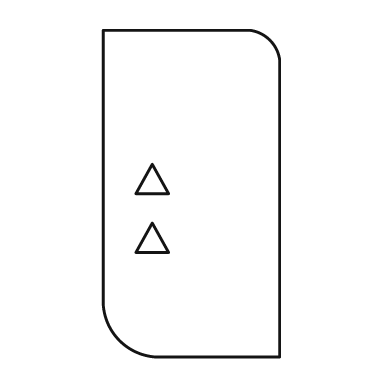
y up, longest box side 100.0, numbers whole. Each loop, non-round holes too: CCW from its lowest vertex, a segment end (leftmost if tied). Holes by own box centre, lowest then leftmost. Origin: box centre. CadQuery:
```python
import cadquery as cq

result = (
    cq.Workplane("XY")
    .moveTo(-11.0, -50.0)
    .lineTo(27.0, -50.0)
    .lineTo(27.0, 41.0)
    .threePointArc((24.0, 47.0), (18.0, 50.0))
    .lineTo(-27.0, 50.0)
    .lineTo(-27.0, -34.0)
    .threePointArc((-22.0, -45.0), (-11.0, -50.0))
    .close()
    .moveTo(-17.0, -18.0)
    .lineTo(-7.0, -18.0)
    .lineTo(-12.0, -9.0)
    .close()
    .moveTo(-17.0, 0.0)
    .lineTo(-7.0, 0.0)
    .lineTo(-12.0, 9.0)
    .close()
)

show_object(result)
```